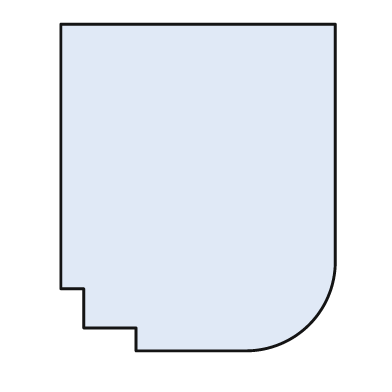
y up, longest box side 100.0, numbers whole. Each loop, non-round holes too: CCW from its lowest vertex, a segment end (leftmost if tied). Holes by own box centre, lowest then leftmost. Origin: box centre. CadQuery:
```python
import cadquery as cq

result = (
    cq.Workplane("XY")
    .moveTo(-19.0, -50.0)
    .lineTo(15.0, -50.0)
    .threePointArc((34.0, -42.0), (42.0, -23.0))
    .lineTo(42.0, 50.0)
    .lineTo(-42.0, 50.0)
    .lineTo(-42.0, -31.0)
    .lineTo(-35.0, -31.0)
    .lineTo(-35.0, -43.0)
    .lineTo(-19.0, -43.0)
    .close()
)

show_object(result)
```